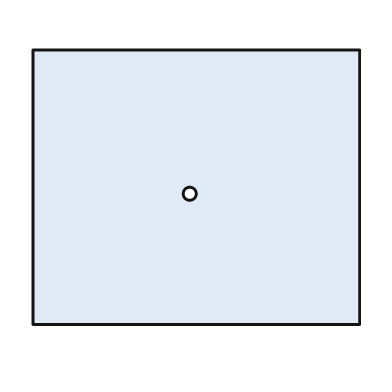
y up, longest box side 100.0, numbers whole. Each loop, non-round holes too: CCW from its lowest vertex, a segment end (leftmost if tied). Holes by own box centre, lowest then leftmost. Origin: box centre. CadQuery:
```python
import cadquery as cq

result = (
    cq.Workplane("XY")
    .moveTo(-50.0, -42.0)
    .lineTo(50.0, -42.0)
    .lineTo(50.0, 42.0)
    .lineTo(-50.0, 42.0)
    .close()
    .moveTo(-2.0, -2.0)
    .circle(2.0)
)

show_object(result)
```